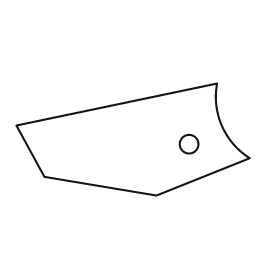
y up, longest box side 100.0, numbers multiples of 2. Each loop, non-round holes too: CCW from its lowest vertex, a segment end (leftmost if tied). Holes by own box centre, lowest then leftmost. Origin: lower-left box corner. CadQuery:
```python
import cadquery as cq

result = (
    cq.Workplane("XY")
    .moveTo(60.0, 0.0)
    .lineTo(100.0, 16.0)
    .threePointArc((88.0, 30.0), (86.0, 48.0))
    .lineTo(0.0, 30.0)
    .lineTo(12.0, 8.0)
    .close()
    .moveTo(74.0, 22.0)
    .circle(4.0)
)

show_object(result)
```